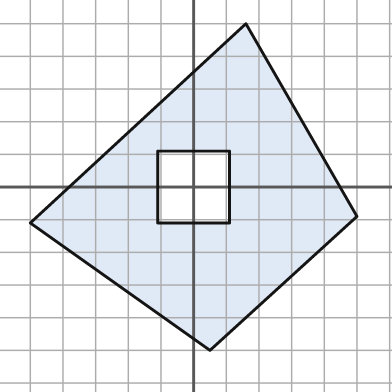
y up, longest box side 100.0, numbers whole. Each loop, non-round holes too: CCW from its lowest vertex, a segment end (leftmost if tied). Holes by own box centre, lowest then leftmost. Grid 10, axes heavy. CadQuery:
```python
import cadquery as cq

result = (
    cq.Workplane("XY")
    .moveTo(5.0, -50.0)
    .lineTo(50.0, -9.0)
    .lineTo(16.0, 50.0)
    .lineTo(-50.0, -11.0)
    .close()
    .moveTo(-11.0, -11.0)
    .lineTo(11.0, -11.0)
    .lineTo(11.0, 11.0)
    .lineTo(-11.0, 11.0)
    .close()
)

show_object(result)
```